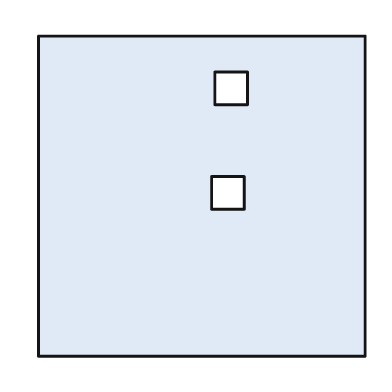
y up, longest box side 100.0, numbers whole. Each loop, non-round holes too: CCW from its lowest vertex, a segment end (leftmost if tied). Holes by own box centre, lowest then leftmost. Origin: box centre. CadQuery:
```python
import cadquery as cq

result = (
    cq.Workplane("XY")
    .moveTo(-50.0, -49.0)
    .lineTo(50.0, -49.0)
    .lineTo(50.0, 49.0)
    .lineTo(-50.0, 49.0)
    .close()
    .moveTo(3.0, -4.0)
    .lineTo(13.0, -4.0)
    .lineTo(13.0, 6.0)
    .lineTo(3.0, 6.0)
    .close()
    .moveTo(4.0, 28.0)
    .lineTo(14.0, 28.0)
    .lineTo(14.0, 38.0)
    .lineTo(4.0, 38.0)
    .close()
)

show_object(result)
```